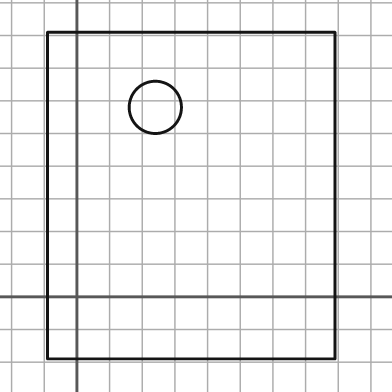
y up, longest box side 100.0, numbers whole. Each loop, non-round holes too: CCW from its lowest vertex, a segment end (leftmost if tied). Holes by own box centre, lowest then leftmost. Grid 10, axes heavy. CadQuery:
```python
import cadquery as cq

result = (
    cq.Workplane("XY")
    .moveTo(-9.0, -19.0)
    .lineTo(79.0, -19.0)
    .lineTo(79.0, 81.0)
    .lineTo(-9.0, 81.0)
    .close()
    .moveTo(24.0, 58.0)
    .circle(8.0)
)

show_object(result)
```